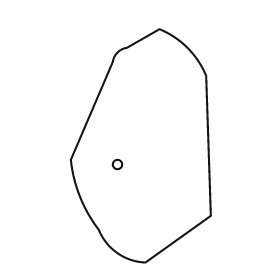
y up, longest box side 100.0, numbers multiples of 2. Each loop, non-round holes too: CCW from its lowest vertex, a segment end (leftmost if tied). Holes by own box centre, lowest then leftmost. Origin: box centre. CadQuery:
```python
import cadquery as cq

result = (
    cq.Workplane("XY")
    .moveTo(2.0, -50.0)
    .lineTo(30.0, -30.0)
    .lineTo(28.0, 30.0)
    .threePointArc((20.0, 42.0), (8.0, 50.0))
    .lineTo(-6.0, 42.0)
    .threePointArc((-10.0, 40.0), (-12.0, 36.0))
    .lineTo(-30.0, -6.0)
    .threePointArc((-26.0, -22.0), (-18.0, -36.0))
    .threePointArc((-10.0, -46.0), (2.0, -50.0))
    .close()
    .moveTo(-10.0, -8.0)
    .circle(2.0)
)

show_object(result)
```